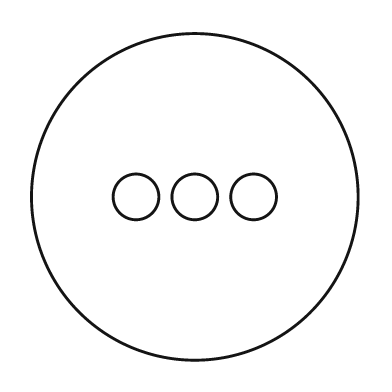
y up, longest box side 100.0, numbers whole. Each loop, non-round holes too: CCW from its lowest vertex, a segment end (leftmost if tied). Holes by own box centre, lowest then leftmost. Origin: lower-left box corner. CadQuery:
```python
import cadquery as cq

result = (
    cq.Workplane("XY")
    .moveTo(50.0, 50.0)
    .circle(50.0)
    .moveTo(32.0, 50.0)
    .circle(7.0)
    .moveTo(50.0, 50.0)
    .circle(7.0)
    .moveTo(68.0, 50.0)
    .circle(7.0)
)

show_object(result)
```